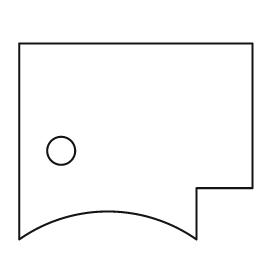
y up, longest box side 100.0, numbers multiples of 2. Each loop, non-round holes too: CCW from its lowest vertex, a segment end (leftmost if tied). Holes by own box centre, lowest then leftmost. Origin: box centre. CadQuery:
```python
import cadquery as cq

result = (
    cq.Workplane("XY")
    .moveTo(-50.0, -42.0)
    .threePointArc((-12.0, -30.0), (26.0, -42.0))
    .lineTo(26.0, -20.0)
    .lineTo(50.0, -20.0)
    .lineTo(50.0, 42.0)
    .lineTo(-50.0, 42.0)
    .close()
    .moveTo(-32.0, -4.0)
    .circle(6.0)
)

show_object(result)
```